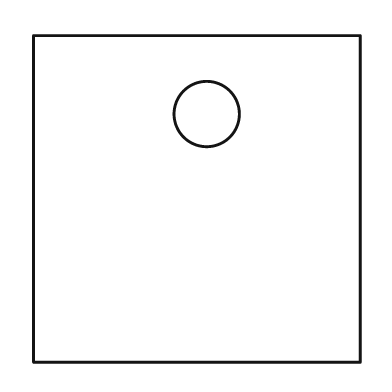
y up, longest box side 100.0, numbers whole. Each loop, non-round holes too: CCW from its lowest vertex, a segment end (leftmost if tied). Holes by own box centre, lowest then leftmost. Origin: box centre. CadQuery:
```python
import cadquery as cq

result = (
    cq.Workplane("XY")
    .moveTo(-50.0, -50.0)
    .lineTo(50.0, -50.0)
    .lineTo(50.0, 50.0)
    .lineTo(-50.0, 50.0)
    .close()
    .moveTo(3.0, 26.0)
    .circle(10.0)
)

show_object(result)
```